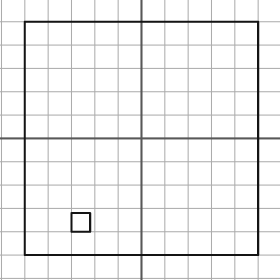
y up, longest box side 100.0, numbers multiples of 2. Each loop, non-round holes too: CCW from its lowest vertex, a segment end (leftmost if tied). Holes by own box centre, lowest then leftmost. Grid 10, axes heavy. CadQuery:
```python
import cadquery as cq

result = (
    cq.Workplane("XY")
    .moveTo(-50.0, -50.0)
    .lineTo(50.0, -50.0)
    .lineTo(50.0, 50.0)
    .lineTo(-50.0, 50.0)
    .close()
    .moveTo(-30.0, -40.0)
    .lineTo(-22.0, -40.0)
    .lineTo(-22.0, -32.0)
    .lineTo(-30.0, -32.0)
    .close()
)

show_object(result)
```